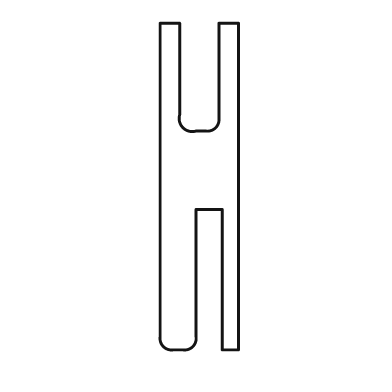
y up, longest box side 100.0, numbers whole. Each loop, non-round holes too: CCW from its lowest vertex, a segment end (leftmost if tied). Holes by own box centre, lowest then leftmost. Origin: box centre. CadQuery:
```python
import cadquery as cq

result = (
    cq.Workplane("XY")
    .moveTo(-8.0, -50.0)
    .lineTo(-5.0, -50.0)
    .threePointArc((-2.0, -49.0), (-1.0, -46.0))
    .lineTo(-1.0, -7.0)
    .lineTo(7.0, -7.0)
    .lineTo(7.0, -50.0)
    .lineTo(12.0, -50.0)
    .lineTo(12.0, 50.0)
    .lineTo(6.0, 50.0)
    .lineTo(6.0, 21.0)
    .threePointArc((5.0, 18.0), (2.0, 17.0))
    .lineTo(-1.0, 17.0)
    .threePointArc((-5.0, 18.0), (-6.0, 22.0))
    .lineTo(-6.0, 50.0)
    .lineTo(-12.0, 50.0)
    .lineTo(-12.0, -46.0)
    .threePointArc((-11.0, -49.0), (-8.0, -50.0))
    .close()
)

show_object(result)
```